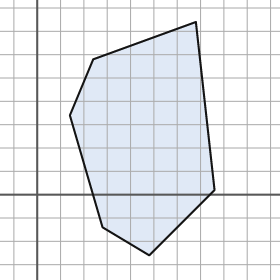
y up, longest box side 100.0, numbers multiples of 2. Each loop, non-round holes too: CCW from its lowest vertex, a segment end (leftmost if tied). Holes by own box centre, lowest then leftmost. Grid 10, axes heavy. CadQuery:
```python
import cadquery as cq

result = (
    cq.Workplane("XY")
    .moveTo(48.0, -26.0)
    .lineTo(76.0, 2.0)
    .lineTo(68.0, 74.0)
    .lineTo(24.0, 58.0)
    .lineTo(14.0, 34.0)
    .lineTo(28.0, -14.0)
    .close()
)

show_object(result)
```